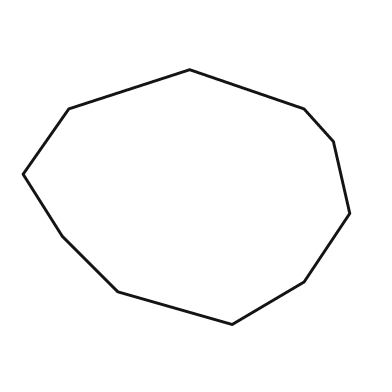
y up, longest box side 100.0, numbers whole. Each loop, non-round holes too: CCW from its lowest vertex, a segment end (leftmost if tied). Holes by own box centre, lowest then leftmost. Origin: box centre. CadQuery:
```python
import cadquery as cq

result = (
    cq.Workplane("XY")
    .moveTo(14.0, -39.0)
    .lineTo(36.0, -26.0)
    .lineTo(50.0, -5.0)
    .lineTo(45.0, 17.0)
    .lineTo(36.0, 27.0)
    .lineTo(1.0, 39.0)
    .lineTo(-36.0, 27.0)
    .lineTo(-50.0, 7.0)
    .lineTo(-38.0, -12.0)
    .lineTo(-21.0, -29.0)
    .close()
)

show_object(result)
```